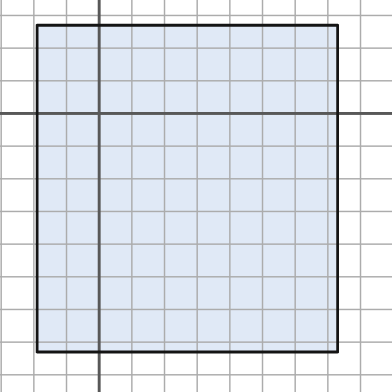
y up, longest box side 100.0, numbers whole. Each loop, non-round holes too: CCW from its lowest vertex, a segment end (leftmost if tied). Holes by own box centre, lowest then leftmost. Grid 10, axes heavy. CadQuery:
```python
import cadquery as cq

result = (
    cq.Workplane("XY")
    .moveTo(-19.0, -73.0)
    .lineTo(73.0, -73.0)
    .lineTo(73.0, 27.0)
    .lineTo(-19.0, 27.0)
    .close()
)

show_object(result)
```